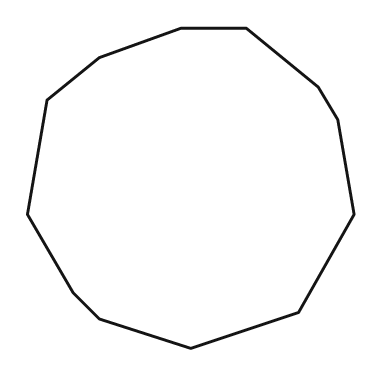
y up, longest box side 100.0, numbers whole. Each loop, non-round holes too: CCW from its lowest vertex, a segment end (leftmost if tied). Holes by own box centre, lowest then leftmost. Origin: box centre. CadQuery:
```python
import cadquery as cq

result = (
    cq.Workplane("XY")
    .moveTo(0.0, -49.0)
    .lineTo(33.0, -38.0)
    .lineTo(50.0, -8.0)
    .lineTo(45.0, 21.0)
    .lineTo(39.0, 31.0)
    .lineTo(17.0, 49.0)
    .lineTo(-3.0, 49.0)
    .lineTo(-28.0, 40.0)
    .lineTo(-44.0, 27.0)
    .lineTo(-50.0, -8.0)
    .lineTo(-36.0, -32.0)
    .lineTo(-28.0, -40.0)
    .close()
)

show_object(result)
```